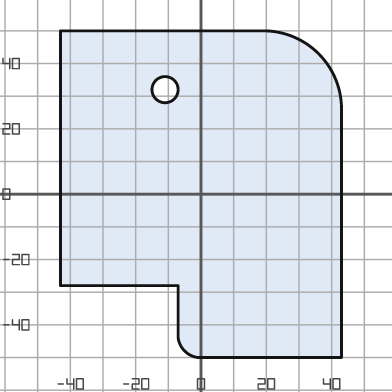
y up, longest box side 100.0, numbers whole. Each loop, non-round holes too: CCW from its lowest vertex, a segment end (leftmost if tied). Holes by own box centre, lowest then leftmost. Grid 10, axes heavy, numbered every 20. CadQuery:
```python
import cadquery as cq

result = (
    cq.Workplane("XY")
    .moveTo(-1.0, -50.0)
    .lineTo(43.0, -50.0)
    .lineTo(43.0, 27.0)
    .threePointArc((36.0, 43.0), (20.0, 50.0))
    .lineTo(-43.0, 50.0)
    .lineTo(-43.0, -28.0)
    .lineTo(-7.0, -28.0)
    .lineTo(-7.0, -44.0)
    .threePointArc((-5.0, -48.0), (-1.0, -50.0))
    .close()
    .moveTo(-11.0, 32.0)
    .circle(4.0)
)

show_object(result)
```